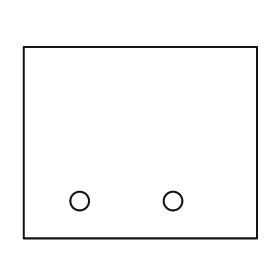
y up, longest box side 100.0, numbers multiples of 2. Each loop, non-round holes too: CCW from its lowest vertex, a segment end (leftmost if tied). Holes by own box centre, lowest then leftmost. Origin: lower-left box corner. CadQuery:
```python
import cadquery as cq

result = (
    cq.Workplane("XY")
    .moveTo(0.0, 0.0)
    .lineTo(100.0, 0.0)
    .lineTo(100.0, 82.0)
    .lineTo(0.0, 82.0)
    .close()
    .moveTo(24.0, 16.0)
    .circle(4.0)
    .moveTo(64.0, 16.0)
    .circle(4.0)
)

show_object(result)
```